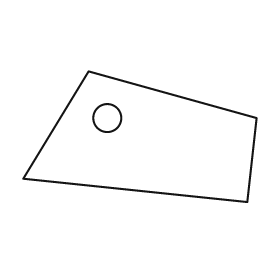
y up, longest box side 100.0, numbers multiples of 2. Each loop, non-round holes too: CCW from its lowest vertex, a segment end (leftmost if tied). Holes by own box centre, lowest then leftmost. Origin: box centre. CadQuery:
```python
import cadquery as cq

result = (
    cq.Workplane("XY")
    .moveTo(46.0, -28.0)
    .lineTo(50.0, 8.0)
    .lineTo(-22.0, 28.0)
    .lineTo(-50.0, -18.0)
    .close()
    .moveTo(-14.0, 8.0)
    .circle(6.0)
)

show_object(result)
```